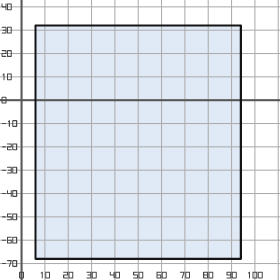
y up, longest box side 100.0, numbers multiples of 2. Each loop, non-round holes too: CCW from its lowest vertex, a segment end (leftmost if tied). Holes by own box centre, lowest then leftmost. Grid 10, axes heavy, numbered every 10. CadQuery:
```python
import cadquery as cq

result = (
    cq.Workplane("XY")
    .moveTo(6.0, -68.0)
    .lineTo(94.0, -68.0)
    .lineTo(94.0, 32.0)
    .lineTo(6.0, 32.0)
    .close()
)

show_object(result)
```